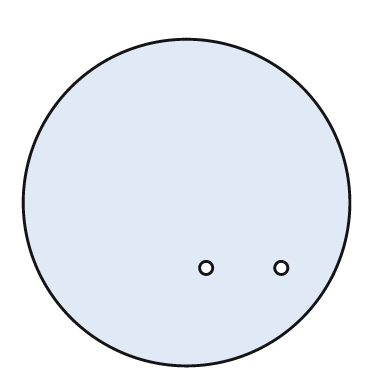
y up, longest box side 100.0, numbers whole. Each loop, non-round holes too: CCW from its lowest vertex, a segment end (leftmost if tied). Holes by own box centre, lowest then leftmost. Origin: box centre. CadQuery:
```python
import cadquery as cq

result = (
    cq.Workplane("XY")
    .moveTo(0.0, 0.0)
    .circle(50.0)
    .moveTo(6.0, -20.0)
    .circle(2.0)
    .moveTo(29.0, -20.0)
    .circle(2.0)
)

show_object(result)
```